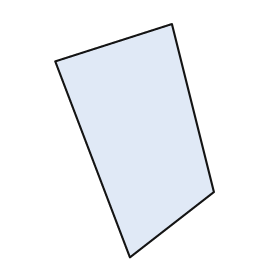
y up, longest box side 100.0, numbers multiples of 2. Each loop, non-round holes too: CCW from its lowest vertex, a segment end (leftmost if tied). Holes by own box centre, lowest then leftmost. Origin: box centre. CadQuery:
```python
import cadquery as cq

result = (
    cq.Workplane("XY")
    .moveTo(-2.0, -50.0)
    .lineTo(34.0, -22.0)
    .lineTo(16.0, 50.0)
    .lineTo(-34.0, 34.0)
    .close()
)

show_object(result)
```